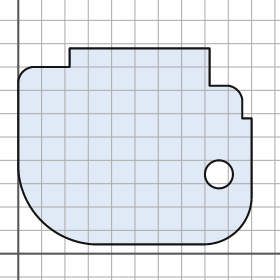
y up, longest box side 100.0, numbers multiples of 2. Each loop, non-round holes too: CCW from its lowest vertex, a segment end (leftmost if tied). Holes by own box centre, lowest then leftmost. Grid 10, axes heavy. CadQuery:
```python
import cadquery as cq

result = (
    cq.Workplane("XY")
    .moveTo(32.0, 4.0)
    .lineTo(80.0, 4.0)
    .threePointArc((94.0, 10.0), (100.0, 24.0))
    .lineTo(100.0, 58.0)
    .lineTo(96.0, 58.0)
    .lineTo(96.0, 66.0)
    .threePointArc((94.0, 70.0), (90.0, 72.0))
    .lineTo(82.0, 72.0)
    .lineTo(82.0, 88.0)
    .lineTo(22.0, 88.0)
    .lineTo(22.0, 80.0)
    .lineTo(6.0, 80.0)
    .threePointArc((2.0, 78.0), (0.0, 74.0))
    .lineTo(0.0, 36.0)
    .threePointArc((10.0, 14.0), (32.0, 4.0))
    .close()
    .moveTo(86.0, 34.0)
    .circle(6.0)
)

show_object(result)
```